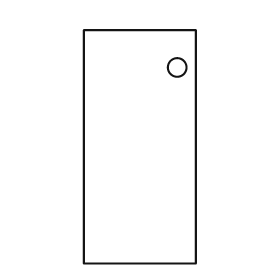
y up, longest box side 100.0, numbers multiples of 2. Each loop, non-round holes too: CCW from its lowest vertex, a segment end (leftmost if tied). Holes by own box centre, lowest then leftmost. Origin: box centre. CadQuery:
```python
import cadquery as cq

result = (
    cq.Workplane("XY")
    .moveTo(-24.0, -50.0)
    .lineTo(24.0, -50.0)
    .lineTo(24.0, 50.0)
    .lineTo(-24.0, 50.0)
    .close()
    .moveTo(16.0, 34.0)
    .circle(4.0)
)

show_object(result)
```